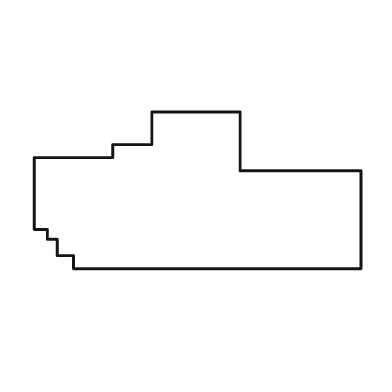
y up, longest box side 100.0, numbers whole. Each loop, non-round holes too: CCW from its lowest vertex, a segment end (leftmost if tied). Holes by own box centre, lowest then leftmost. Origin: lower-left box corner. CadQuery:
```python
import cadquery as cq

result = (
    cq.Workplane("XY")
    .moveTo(12.0, 0.0)
    .lineTo(100.0, 0.0)
    .lineTo(100.0, 30.0)
    .lineTo(63.0, 30.0)
    .lineTo(63.0, 48.0)
    .lineTo(36.0, 48.0)
    .lineTo(36.0, 38.0)
    .lineTo(24.0, 38.0)
    .lineTo(24.0, 34.0)
    .lineTo(0.0, 34.0)
    .lineTo(0.0, 12.0)
    .lineTo(4.0, 12.0)
    .lineTo(4.0, 9.0)
    .lineTo(7.0, 9.0)
    .lineTo(7.0, 4.0)
    .lineTo(12.0, 4.0)
    .close()
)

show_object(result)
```